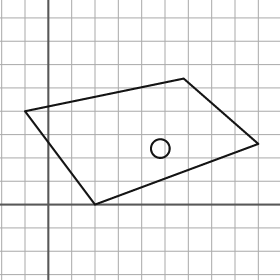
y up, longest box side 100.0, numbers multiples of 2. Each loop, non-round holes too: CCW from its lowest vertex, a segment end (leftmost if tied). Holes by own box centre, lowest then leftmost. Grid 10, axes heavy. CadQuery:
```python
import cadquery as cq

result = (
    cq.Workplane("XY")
    .moveTo(20.0, 0.0)
    .lineTo(90.0, 26.0)
    .lineTo(58.0, 54.0)
    .lineTo(-10.0, 40.0)
    .close()
    .moveTo(48.0, 24.0)
    .circle(4.0)
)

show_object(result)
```